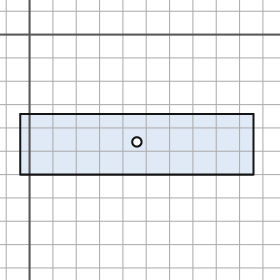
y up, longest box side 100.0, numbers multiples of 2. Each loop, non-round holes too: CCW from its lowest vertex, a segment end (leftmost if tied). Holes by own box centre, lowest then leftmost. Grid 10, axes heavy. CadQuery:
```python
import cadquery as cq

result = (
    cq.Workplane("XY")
    .moveTo(-4.0, -60.0)
    .lineTo(96.0, -60.0)
    .lineTo(96.0, -34.0)
    .lineTo(-4.0, -34.0)
    .close()
    .moveTo(46.0, -46.0)
    .circle(2.0)
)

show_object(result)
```